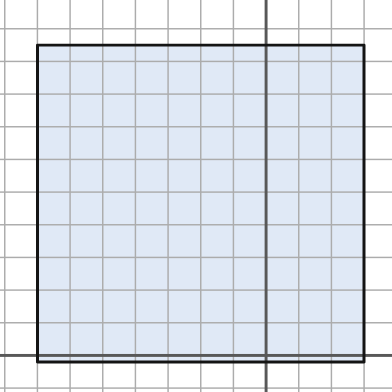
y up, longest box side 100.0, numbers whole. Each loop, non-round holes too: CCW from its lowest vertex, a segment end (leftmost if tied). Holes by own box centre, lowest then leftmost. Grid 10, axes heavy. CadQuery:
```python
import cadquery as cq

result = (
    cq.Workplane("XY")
    .moveTo(-70.0, -2.0)
    .lineTo(30.0, -2.0)
    .lineTo(30.0, 95.0)
    .lineTo(-70.0, 95.0)
    .close()
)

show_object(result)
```